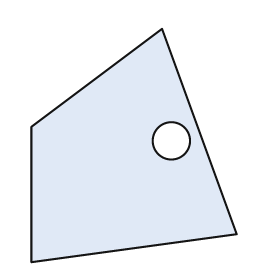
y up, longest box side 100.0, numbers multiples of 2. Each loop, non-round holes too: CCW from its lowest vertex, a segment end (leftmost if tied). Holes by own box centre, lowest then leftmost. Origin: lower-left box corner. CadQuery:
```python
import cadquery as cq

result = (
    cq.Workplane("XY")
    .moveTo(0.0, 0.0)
    .lineTo(88.0, 12.0)
    .lineTo(56.0, 100.0)
    .lineTo(0.0, 58.0)
    .close()
    .moveTo(60.0, 52.0)
    .circle(8.0)
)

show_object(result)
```